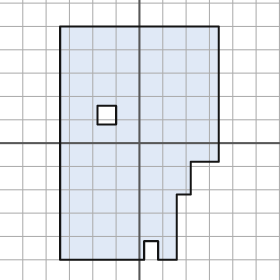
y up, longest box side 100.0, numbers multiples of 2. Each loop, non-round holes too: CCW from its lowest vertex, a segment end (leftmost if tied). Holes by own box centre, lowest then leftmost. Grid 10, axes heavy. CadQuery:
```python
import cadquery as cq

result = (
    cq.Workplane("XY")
    .moveTo(-34.0, -50.0)
    .lineTo(2.0, -50.0)
    .lineTo(2.0, -42.0)
    .lineTo(8.0, -42.0)
    .lineTo(8.0, -50.0)
    .lineTo(16.0, -50.0)
    .lineTo(16.0, -22.0)
    .lineTo(22.0, -22.0)
    .lineTo(22.0, -8.0)
    .lineTo(34.0, -8.0)
    .lineTo(34.0, 50.0)
    .lineTo(-34.0, 50.0)
    .close()
    .moveTo(-18.0, 8.0)
    .lineTo(-10.0, 8.0)
    .lineTo(-10.0, 16.0)
    .lineTo(-18.0, 16.0)
    .close()
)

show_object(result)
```